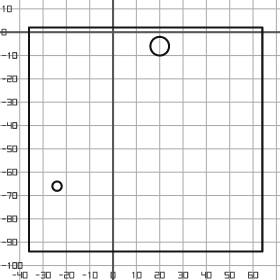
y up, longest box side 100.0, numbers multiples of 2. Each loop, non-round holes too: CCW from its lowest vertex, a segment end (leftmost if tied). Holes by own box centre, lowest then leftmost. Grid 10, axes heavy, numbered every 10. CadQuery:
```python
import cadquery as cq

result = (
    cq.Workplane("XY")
    .moveTo(-36.0, -94.0)
    .lineTo(64.0, -94.0)
    .lineTo(64.0, 2.0)
    .lineTo(-36.0, 2.0)
    .close()
    .moveTo(-24.0, -66.0)
    .circle(2.0)
    .moveTo(20.0, -6.0)
    .circle(4.0)
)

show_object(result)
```